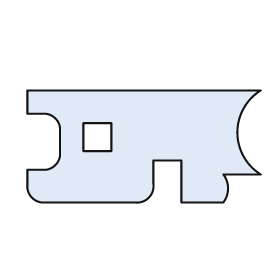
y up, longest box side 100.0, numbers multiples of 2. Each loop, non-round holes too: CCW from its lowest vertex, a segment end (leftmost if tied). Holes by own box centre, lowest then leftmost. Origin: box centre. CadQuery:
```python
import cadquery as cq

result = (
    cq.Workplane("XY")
    .moveTo(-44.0, -24.0)
    .lineTo(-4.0, -24.0)
    .threePointArc((2.0, -22.0), (4.0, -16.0))
    .lineTo(4.0, -6.0)
    .lineTo(16.0, -6.0)
    .lineTo(16.0, -24.0)
    .lineTo(34.0, -24.0)
    .threePointArc((36.0, -18.0), (34.0, -12.0))
    .lineTo(50.0, -12.0)
    .threePointArc((40.0, 6.0), (50.0, 24.0))
    .lineTo(-50.0, 24.0)
    .lineTo(-50.0, 14.0)
    .lineTo(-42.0, 14.0)
    .threePointArc((-38.0, 12.0), (-36.0, 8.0))
    .lineTo(-36.0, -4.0)
    .threePointArc((-38.0, -8.0), (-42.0, -10.0))
    .lineTo(-50.0, -10.0)
    .lineTo(-50.0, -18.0)
    .threePointArc((-48.0, -22.0), (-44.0, -24.0))
    .close()
    .moveTo(-26.0, -2.0)
    .lineTo(-14.0, -2.0)
    .lineTo(-14.0, 10.0)
    .lineTo(-26.0, 10.0)
    .close()
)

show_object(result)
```